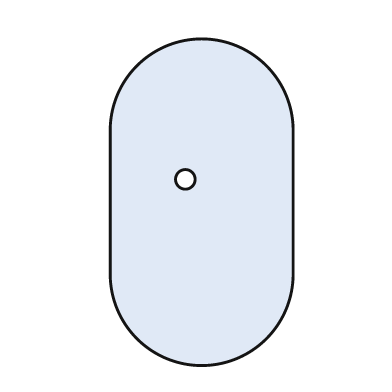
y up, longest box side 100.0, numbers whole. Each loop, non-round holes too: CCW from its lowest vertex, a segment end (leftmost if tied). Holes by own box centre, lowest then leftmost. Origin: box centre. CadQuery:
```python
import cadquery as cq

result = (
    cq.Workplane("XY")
    .moveTo(-28.0, -22.0)
    .threePointArc((0.0, -50.0), (28.0, -22.0))
    .lineTo(28.0, 22.0)
    .threePointArc((0.0, 50.0), (-28.0, 22.0))
    .close()
    .moveTo(-5.0, 7.0)
    .circle(3.0)
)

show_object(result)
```